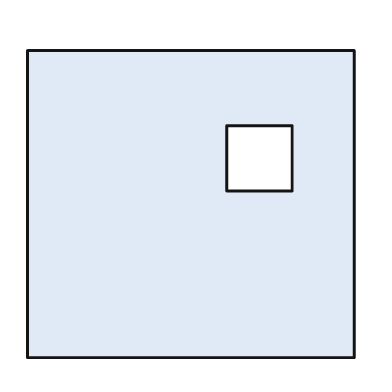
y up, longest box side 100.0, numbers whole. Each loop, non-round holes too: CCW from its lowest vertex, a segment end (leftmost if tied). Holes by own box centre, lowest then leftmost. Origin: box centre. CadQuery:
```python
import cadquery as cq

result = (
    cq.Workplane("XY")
    .moveTo(-50.0, -47.0)
    .lineTo(50.0, -47.0)
    .lineTo(50.0, 47.0)
    .lineTo(-50.0, 47.0)
    .close()
    .moveTo(11.0, 4.0)
    .lineTo(31.0, 4.0)
    .lineTo(31.0, 24.0)
    .lineTo(11.0, 24.0)
    .close()
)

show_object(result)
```